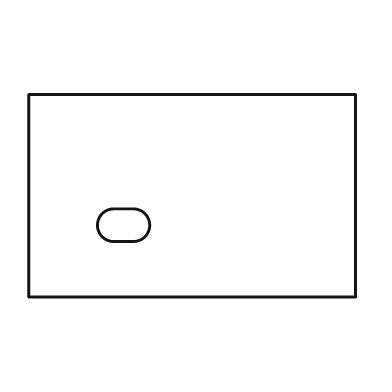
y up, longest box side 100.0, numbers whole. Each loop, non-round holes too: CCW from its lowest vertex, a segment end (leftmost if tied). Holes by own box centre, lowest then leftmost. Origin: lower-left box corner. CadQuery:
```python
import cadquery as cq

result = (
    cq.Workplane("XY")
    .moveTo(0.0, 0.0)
    .lineTo(100.0, 0.0)
    .lineTo(100.0, 62.0)
    .lineTo(0.0, 62.0)
    .close()
    .moveTo(26.0, 17.0)
    .lineTo(32.0, 17.0)
    .threePointArc((37.0, 22.0), (32.0, 27.0))
    .lineTo(26.0, 27.0)
    .threePointArc((21.0, 22.0), (26.0, 17.0))
    .close()
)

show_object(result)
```